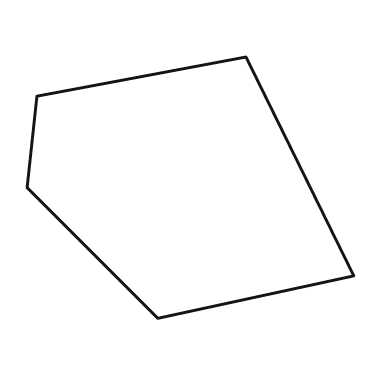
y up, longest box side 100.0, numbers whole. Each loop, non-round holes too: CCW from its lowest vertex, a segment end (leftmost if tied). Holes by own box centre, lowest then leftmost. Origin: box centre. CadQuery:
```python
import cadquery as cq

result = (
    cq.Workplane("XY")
    .moveTo(-10.0, -40.0)
    .lineTo(50.0, -27.0)
    .lineTo(17.0, 40.0)
    .lineTo(-47.0, 28.0)
    .lineTo(-50.0, 0.0)
    .close()
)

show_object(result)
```